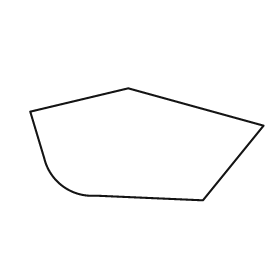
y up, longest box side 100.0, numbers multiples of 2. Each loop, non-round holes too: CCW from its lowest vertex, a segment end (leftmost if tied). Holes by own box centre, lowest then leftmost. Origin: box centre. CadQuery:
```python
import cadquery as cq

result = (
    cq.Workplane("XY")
    .moveTo(24.0, -24.0)
    .lineTo(50.0, 8.0)
    .lineTo(-8.0, 24.0)
    .lineTo(-50.0, 14.0)
    .lineTo(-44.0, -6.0)
    .threePointArc((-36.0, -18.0), (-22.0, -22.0))
    .close()
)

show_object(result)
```